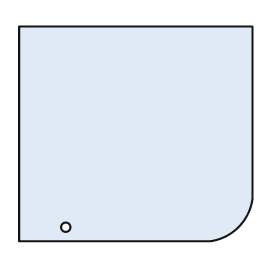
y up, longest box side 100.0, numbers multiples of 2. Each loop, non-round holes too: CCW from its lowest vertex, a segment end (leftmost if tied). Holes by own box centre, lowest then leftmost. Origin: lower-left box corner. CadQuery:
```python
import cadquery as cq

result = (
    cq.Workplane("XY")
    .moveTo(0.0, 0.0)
    .lineTo(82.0, 0.0)
    .threePointArc((94.0, 6.0), (100.0, 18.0))
    .lineTo(100.0, 92.0)
    .lineTo(0.0, 92.0)
    .close()
    .moveTo(20.0, 6.0)
    .circle(2.0)
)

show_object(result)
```